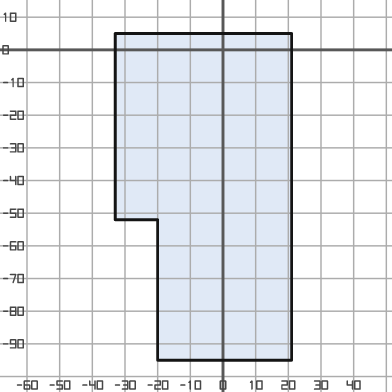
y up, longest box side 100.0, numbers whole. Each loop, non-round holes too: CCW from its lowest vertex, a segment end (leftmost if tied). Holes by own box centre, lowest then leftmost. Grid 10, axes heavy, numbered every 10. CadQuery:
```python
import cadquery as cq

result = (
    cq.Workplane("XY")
    .moveTo(-20.0, -95.0)
    .lineTo(21.0, -95.0)
    .lineTo(21.0, 5.0)
    .lineTo(-33.0, 5.0)
    .lineTo(-33.0, -52.0)
    .lineTo(-20.0, -52.0)
    .close()
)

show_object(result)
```